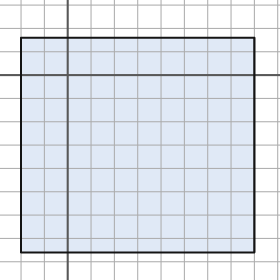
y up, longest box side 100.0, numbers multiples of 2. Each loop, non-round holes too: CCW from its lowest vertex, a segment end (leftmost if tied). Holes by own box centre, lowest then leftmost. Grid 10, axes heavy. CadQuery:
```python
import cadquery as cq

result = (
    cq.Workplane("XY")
    .moveTo(-20.0, -76.0)
    .lineTo(80.0, -76.0)
    .lineTo(80.0, 16.0)
    .lineTo(-20.0, 16.0)
    .close()
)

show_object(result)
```